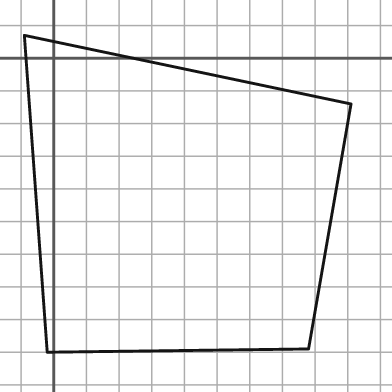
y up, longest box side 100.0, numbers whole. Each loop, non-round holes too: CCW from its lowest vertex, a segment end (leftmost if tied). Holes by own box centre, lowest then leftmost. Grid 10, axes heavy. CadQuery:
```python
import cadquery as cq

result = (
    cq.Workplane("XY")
    .moveTo(-2.0, -90.0)
    .lineTo(78.0, -89.0)
    .lineTo(91.0, -14.0)
    .lineTo(-9.0, 7.0)
    .close()
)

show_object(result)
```